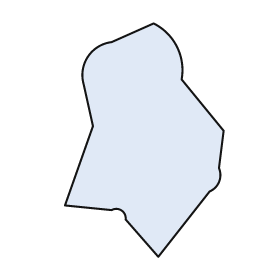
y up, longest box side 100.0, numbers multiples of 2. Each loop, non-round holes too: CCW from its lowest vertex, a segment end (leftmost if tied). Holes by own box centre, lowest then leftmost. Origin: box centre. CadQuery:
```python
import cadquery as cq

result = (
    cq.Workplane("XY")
    .moveTo(6.0, -50.0)
    .lineTo(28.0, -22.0)
    .threePointArc((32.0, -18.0), (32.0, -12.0))
    .lineTo(34.0, 4.0)
    .lineTo(16.0, 26.0)
    .threePointArc((14.0, 40.0), (4.0, 50.0))
    .lineTo(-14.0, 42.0)
    .threePointArc((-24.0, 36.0), (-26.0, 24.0))
    .lineTo(-22.0, 6.0)
    .lineTo(-34.0, -28.0)
    .lineTo(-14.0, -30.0)
    .threePointArc((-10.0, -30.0), (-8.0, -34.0))
    .close()
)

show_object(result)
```